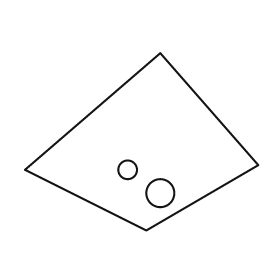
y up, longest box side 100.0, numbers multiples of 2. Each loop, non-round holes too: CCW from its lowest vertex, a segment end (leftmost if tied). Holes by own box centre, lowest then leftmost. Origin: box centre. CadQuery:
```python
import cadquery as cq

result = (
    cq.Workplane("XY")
    .moveTo(2.0, -38.0)
    .lineTo(50.0, -10.0)
    .lineTo(8.0, 38.0)
    .lineTo(-50.0, -12.0)
    .close()
    .moveTo(8.0, -22.0)
    .circle(6.0)
    .moveTo(-6.0, -12.0)
    .circle(4.0)
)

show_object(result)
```